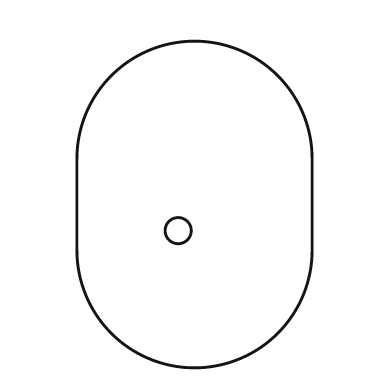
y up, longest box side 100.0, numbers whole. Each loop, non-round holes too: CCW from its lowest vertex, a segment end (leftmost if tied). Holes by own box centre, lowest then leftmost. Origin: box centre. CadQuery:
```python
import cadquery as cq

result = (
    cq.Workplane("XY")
    .moveTo(-36.0, -14.0)
    .threePointArc((0.0, -50.0), (36.0, -14.0))
    .lineTo(36.0, 14.0)
    .threePointArc((0.0, 50.0), (-36.0, 14.0))
    .close()
    .moveTo(-5.0, -8.0)
    .circle(4.0)
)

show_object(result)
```